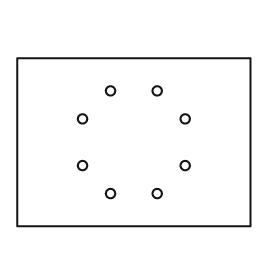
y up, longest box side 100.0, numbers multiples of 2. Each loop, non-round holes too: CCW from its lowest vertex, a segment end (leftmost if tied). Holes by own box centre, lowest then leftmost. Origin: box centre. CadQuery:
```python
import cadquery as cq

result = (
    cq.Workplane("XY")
    .moveTo(-50.0, -36.0)
    .lineTo(50.0, -36.0)
    .lineTo(50.0, 36.0)
    .lineTo(-50.0, 36.0)
    .close()
    .moveTo(-10.0, -22.0)
    .circle(2.0)
    .moveTo(10.0, -22.0)
    .circle(2.0)
    .moveTo(-22.0, -10.0)
    .circle(2.0)
    .moveTo(22.0, -10.0)
    .circle(2.0)
    .moveTo(-22.0, 10.0)
    .circle(2.0)
    .moveTo(22.0, 10.0)
    .circle(2.0)
    .moveTo(-10.0, 22.0)
    .circle(2.0)
    .moveTo(10.0, 22.0)
    .circle(2.0)
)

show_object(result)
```